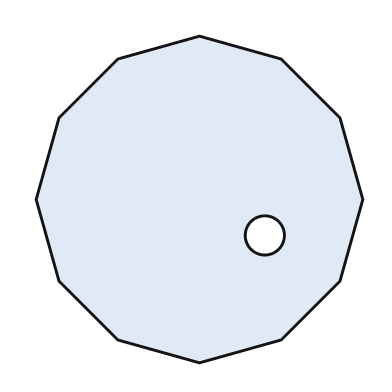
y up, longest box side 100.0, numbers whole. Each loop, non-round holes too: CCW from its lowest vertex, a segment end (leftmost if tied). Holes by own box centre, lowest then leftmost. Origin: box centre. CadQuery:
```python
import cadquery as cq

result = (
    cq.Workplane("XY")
    .moveTo(0.0, -50.0)
    .lineTo(25.0, -43.0)
    .lineTo(43.0, -25.0)
    .lineTo(50.0, 0.0)
    .lineTo(43.0, 25.0)
    .lineTo(25.0, 43.0)
    .lineTo(0.0, 50.0)
    .lineTo(-25.0, 43.0)
    .lineTo(-43.0, 25.0)
    .lineTo(-50.0, 0.0)
    .lineTo(-43.0, -25.0)
    .lineTo(-25.0, -43.0)
    .close()
    .moveTo(20.0, -11.0)
    .circle(6.0)
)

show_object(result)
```